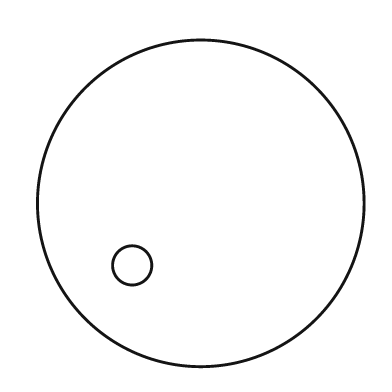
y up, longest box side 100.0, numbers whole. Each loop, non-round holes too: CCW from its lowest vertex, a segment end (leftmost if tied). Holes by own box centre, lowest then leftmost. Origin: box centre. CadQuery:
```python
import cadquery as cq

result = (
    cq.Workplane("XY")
    .moveTo(0.0, 0.0)
    .circle(50.0)
    .moveTo(-21.0, -19.0)
    .circle(6.0)
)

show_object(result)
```